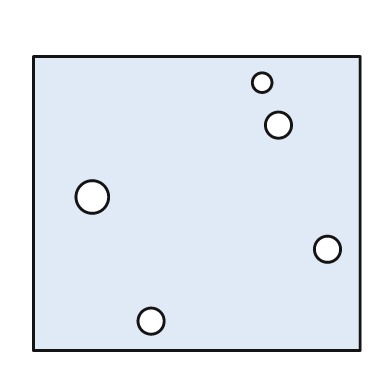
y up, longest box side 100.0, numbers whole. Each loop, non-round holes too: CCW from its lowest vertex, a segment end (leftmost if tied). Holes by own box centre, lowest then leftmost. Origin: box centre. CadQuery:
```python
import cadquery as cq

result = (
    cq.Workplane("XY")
    .moveTo(-50.0, -45.0)
    .lineTo(50.0, -45.0)
    .lineTo(50.0, 45.0)
    .lineTo(-50.0, 45.0)
    .close()
    .moveTo(-14.0, -36.0)
    .circle(4.0)
    .moveTo(40.0, -14.0)
    .circle(4.0)
    .moveTo(-32.0, 2.0)
    .circle(5.0)
    .moveTo(25.0, 24.0)
    .circle(4.0)
    .moveTo(20.0, 37.0)
    .circle(3.0)
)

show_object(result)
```